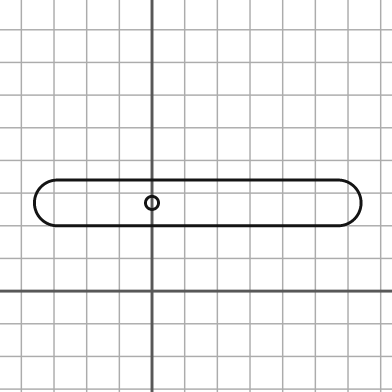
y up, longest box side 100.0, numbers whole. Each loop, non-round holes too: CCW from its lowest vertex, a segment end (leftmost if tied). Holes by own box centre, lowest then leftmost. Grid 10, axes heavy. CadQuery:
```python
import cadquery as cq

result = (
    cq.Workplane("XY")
    .moveTo(-29.0, 20.0)
    .lineTo(57.0, 20.0)
    .threePointArc((64.0, 27.0), (57.0, 34.0))
    .lineTo(-29.0, 34.0)
    .threePointArc((-36.0, 27.0), (-29.0, 20.0))
    .close()
    .moveTo(0.0, 27.0)
    .circle(2.0)
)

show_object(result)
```